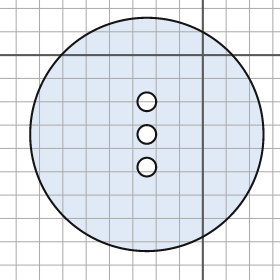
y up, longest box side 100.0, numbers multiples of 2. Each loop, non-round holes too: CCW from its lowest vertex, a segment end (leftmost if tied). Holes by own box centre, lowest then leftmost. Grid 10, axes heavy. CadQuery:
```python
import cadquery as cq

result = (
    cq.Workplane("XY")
    .moveTo(-24.0, -34.0)
    .circle(50.0)
    .moveTo(-24.0, -48.0)
    .circle(4.0)
    .moveTo(-24.0, -34.0)
    .circle(4.0)
    .moveTo(-24.0, -20.0)
    .circle(4.0)
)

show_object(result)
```